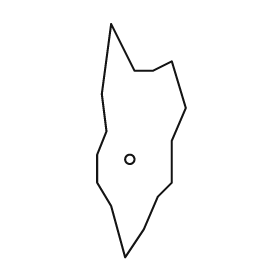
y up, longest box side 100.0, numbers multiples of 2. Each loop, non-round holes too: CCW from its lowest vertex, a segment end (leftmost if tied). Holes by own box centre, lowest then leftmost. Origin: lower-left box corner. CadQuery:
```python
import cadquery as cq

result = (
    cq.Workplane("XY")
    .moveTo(12.0, 0.0)
    .lineTo(20.0, 12.0)
    .lineTo(26.0, 26.0)
    .lineTo(32.0, 32.0)
    .lineTo(32.0, 50.0)
    .lineTo(38.0, 64.0)
    .lineTo(32.0, 84.0)
    .lineTo(24.0, 80.0)
    .lineTo(16.0, 80.0)
    .lineTo(6.0, 100.0)
    .lineTo(2.0, 70.0)
    .lineTo(4.0, 54.0)
    .lineTo(0.0, 44.0)
    .lineTo(0.0, 32.0)
    .lineTo(6.0, 22.0)
    .close()
    .moveTo(14.0, 42.0)
    .circle(2.0)
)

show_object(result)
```